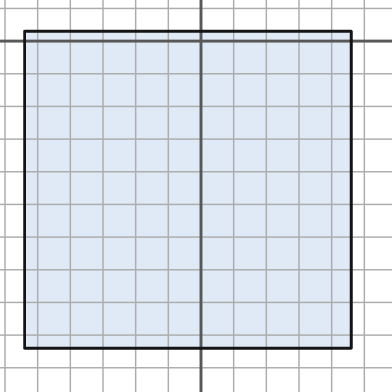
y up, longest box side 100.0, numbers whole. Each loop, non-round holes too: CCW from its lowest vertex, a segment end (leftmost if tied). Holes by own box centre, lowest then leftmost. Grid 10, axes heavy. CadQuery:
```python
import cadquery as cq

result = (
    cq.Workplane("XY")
    .moveTo(-54.0, -94.0)
    .lineTo(46.0, -94.0)
    .lineTo(46.0, 3.0)
    .lineTo(-54.0, 3.0)
    .close()
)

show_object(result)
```